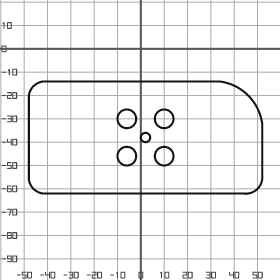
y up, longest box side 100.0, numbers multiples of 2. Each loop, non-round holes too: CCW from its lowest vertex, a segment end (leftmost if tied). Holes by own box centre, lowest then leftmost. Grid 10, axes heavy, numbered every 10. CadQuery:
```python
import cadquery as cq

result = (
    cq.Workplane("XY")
    .moveTo(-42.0, -62.0)
    .lineTo(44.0, -62.0)
    .threePointArc((50.0, -60.0), (52.0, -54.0))
    .lineTo(52.0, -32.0)
    .threePointArc((46.0, -20.0), (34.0, -14.0))
    .lineTo(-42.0, -14.0)
    .threePointArc((-46.0, -16.0), (-48.0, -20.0))
    .lineTo(-48.0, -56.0)
    .threePointArc((-46.0, -60.0), (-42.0, -62.0))
    .close()
    .moveTo(-6.0, -46.0)
    .circle(4.0)
    .moveTo(10.0, -46.0)
    .circle(4.0)
    .moveTo(2.0, -38.0)
    .circle(2.0)
    .moveTo(-6.0, -30.0)
    .circle(4.0)
    .moveTo(10.0, -30.0)
    .circle(4.0)
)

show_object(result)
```